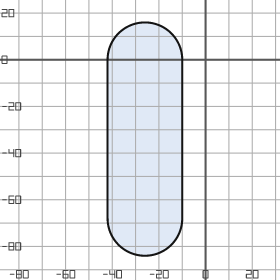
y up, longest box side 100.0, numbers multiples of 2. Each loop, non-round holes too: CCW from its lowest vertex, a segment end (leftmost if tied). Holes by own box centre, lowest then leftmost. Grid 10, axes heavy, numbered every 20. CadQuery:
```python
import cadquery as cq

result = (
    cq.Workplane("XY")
    .moveTo(-42.0, -68.0)
    .threePointArc((-26.0, -84.0), (-10.0, -68.0))
    .lineTo(-10.0, 0.0)
    .threePointArc((-26.0, 16.0), (-42.0, 0.0))
    .close()
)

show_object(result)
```